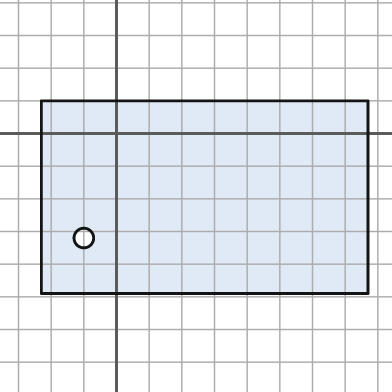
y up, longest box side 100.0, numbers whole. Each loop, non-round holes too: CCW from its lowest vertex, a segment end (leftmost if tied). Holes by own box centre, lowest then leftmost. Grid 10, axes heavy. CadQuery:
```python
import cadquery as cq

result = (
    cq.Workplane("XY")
    .moveTo(-23.0, -49.0)
    .lineTo(77.0, -49.0)
    .lineTo(77.0, 10.0)
    .lineTo(-23.0, 10.0)
    .close()
    .moveTo(-10.0, -32.0)
    .circle(3.0)
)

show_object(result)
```